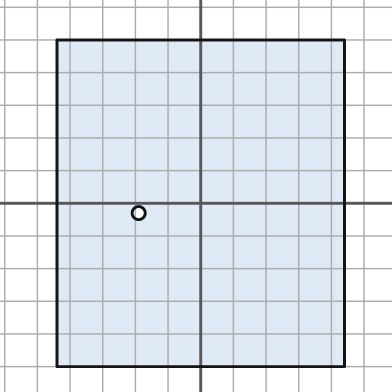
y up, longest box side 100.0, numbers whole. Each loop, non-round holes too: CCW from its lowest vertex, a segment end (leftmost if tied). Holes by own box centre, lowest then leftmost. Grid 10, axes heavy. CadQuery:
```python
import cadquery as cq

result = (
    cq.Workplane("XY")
    .moveTo(-44.0, -50.0)
    .lineTo(44.0, -50.0)
    .lineTo(44.0, 50.0)
    .lineTo(-44.0, 50.0)
    .close()
    .moveTo(-19.0, -3.0)
    .circle(2.0)
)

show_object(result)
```